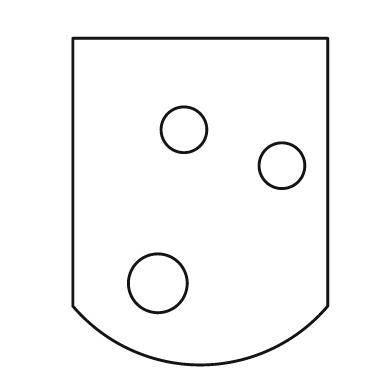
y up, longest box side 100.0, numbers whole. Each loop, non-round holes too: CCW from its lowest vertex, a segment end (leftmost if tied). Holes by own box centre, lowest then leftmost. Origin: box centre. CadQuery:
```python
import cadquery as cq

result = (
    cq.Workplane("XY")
    .moveTo(-39.0, -32.0)
    .threePointArc((0.0, -50.0), (39.0, -32.0))
    .lineTo(39.0, 50.0)
    .lineTo(-39.0, 50.0)
    .close()
    .moveTo(-13.0, -25.0)
    .circle(9.0)
    .moveTo(25.0, 11.0)
    .circle(7.0)
    .moveTo(-5.0, 22.0)
    .circle(7.0)
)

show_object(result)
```